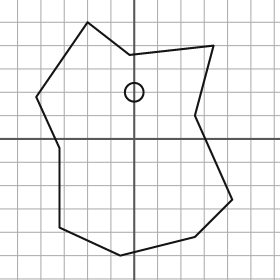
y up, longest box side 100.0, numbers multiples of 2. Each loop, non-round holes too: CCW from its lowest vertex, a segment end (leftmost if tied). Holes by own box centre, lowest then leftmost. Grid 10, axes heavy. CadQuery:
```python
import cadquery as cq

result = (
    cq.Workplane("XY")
    .moveTo(-6.0, -50.0)
    .lineTo(26.0, -42.0)
    .lineTo(42.0, -26.0)
    .lineTo(26.0, 10.0)
    .lineTo(34.0, 40.0)
    .lineTo(-2.0, 36.0)
    .lineTo(-20.0, 50.0)
    .lineTo(-42.0, 18.0)
    .lineTo(-32.0, -4.0)
    .lineTo(-32.0, -38.0)
    .close()
    .moveTo(0.0, 20.0)
    .circle(4.0)
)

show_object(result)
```